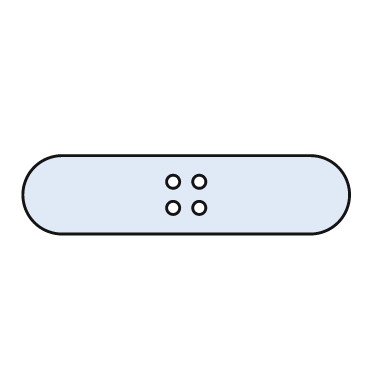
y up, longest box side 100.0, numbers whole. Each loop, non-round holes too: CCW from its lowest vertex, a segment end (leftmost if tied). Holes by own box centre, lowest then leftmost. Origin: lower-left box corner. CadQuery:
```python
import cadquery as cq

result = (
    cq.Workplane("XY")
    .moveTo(12.0, 0.0)
    .lineTo(88.0, 0.0)
    .threePointArc((100.0, 12.0), (88.0, 24.0))
    .lineTo(12.0, 24.0)
    .threePointArc((0.0, 12.0), (12.0, 0.0))
    .close()
    .moveTo(46.0, 8.0)
    .circle(2.0)
    .moveTo(54.0, 8.0)
    .circle(2.0)
    .moveTo(46.0, 16.0)
    .circle(2.0)
    .moveTo(54.0, 16.0)
    .circle(2.0)
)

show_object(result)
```